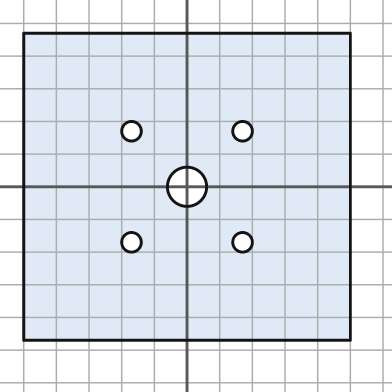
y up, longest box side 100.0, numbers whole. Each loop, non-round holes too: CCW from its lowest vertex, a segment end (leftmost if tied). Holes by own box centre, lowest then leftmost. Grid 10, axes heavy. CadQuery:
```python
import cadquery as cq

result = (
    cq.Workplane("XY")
    .moveTo(-50.0, -47.0)
    .lineTo(50.0, -47.0)
    .lineTo(50.0, 47.0)
    .lineTo(-50.0, 47.0)
    .close()
    .moveTo(-17.0, -17.0)
    .circle(3.0)
    .moveTo(17.0, -17.0)
    .circle(3.0)
    .moveTo(0.0, 0.0)
    .circle(6.0)
    .moveTo(-17.0, 17.0)
    .circle(3.0)
    .moveTo(17.0, 17.0)
    .circle(3.0)
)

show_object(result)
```